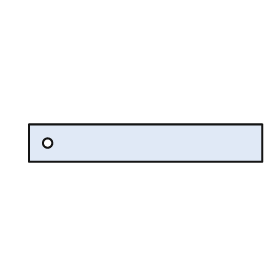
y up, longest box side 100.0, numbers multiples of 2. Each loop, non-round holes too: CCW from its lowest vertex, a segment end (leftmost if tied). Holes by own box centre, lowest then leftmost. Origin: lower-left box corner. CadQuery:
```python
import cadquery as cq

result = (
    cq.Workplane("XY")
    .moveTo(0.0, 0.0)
    .lineTo(100.0, 0.0)
    .lineTo(100.0, 16.0)
    .lineTo(0.0, 16.0)
    .close()
    .moveTo(8.0, 8.0)
    .circle(2.0)
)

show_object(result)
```